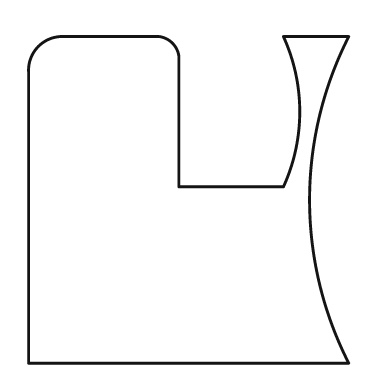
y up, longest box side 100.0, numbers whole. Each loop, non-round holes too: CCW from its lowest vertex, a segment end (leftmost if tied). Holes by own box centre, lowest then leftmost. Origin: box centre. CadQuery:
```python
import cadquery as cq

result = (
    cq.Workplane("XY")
    .moveTo(-49.0, -50.0)
    .lineTo(49.0, -50.0)
    .threePointArc((37.0, 0.0), (49.0, 50.0))
    .lineTo(29.0, 50.0)
    .threePointArc((34.0, 27.0), (29.0, 4.0))
    .lineTo(-3.0, 4.0)
    .lineTo(-3.0, 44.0)
    .threePointArc((-5.0, 48.0), (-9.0, 50.0))
    .lineTo(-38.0, 50.0)
    .threePointArc((-46.0, 47.0), (-49.0, 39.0))
    .close()
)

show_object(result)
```